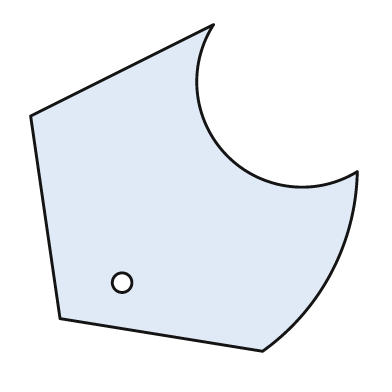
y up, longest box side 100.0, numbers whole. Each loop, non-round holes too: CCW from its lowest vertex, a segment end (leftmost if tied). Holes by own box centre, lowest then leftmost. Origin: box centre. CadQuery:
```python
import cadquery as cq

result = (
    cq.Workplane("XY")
    .moveTo(21.0, -50.0)
    .threePointArc((42.0, -26.0), (50.0, 5.0))
    .threePointArc((10.0, 10.0), (6.0, 50.0))
    .lineTo(-50.0, 22.0)
    .lineTo(-41.0, -40.0)
    .close()
    .moveTo(-22.0, -29.0)
    .circle(3.0)
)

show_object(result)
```